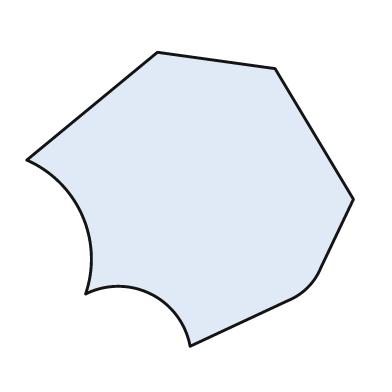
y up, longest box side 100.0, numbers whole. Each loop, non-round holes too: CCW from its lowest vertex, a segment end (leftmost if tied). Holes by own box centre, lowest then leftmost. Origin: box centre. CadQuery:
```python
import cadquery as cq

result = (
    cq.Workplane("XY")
    .moveTo(0.0, -45.0)
    .lineTo(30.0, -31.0)
    .threePointArc((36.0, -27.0), (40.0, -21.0))
    .lineTo(50.0, 0.0)
    .lineTo(26.0, 40.0)
    .lineTo(-10.0, 45.0)
    .lineTo(-50.0, 12.0)
    .threePointArc((-33.0, -5.0), (-32.0, -29.0))
    .threePointArc((-12.0, -29.0), (0.0, -45.0))
    .close()
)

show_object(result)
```